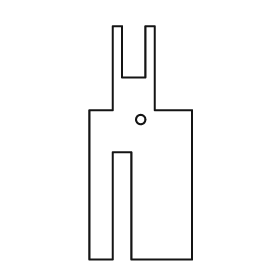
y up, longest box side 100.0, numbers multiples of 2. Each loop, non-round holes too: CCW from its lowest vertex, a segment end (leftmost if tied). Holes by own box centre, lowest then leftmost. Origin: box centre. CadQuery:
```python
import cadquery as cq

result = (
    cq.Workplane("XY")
    .moveTo(-22.0, -50.0)
    .lineTo(-12.0, -50.0)
    .lineTo(-12.0, -4.0)
    .lineTo(-4.0, -4.0)
    .lineTo(-4.0, -50.0)
    .lineTo(22.0, -50.0)
    .lineTo(22.0, 14.0)
    .lineTo(6.0, 14.0)
    .lineTo(6.0, 50.0)
    .lineTo(2.0, 50.0)
    .lineTo(2.0, 28.0)
    .lineTo(-8.0, 28.0)
    .lineTo(-8.0, 50.0)
    .lineTo(-12.0, 50.0)
    .lineTo(-12.0, 14.0)
    .lineTo(-22.0, 14.0)
    .close()
    .moveTo(0.0, 10.0)
    .circle(2.0)
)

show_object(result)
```